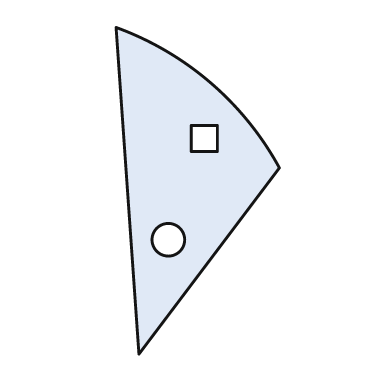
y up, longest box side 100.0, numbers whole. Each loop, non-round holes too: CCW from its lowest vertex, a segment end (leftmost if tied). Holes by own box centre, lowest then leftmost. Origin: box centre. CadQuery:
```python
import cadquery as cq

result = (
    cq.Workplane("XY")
    .moveTo(-18.0, -50.0)
    .lineTo(25.0, 7.0)
    .threePointArc((4.0, 33.0), (-25.0, 50.0))
    .close()
    .moveTo(-9.0, -15.0)
    .circle(5.0)
    .moveTo(-2.0, 12.0)
    .lineTo(6.0, 12.0)
    .lineTo(6.0, 20.0)
    .lineTo(-2.0, 20.0)
    .close()
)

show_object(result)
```